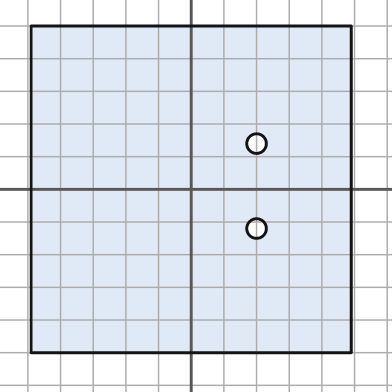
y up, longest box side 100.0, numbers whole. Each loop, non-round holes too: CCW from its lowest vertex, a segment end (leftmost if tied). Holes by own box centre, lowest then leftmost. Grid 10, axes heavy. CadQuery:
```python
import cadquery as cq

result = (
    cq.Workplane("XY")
    .moveTo(-49.0, -50.0)
    .lineTo(49.0, -50.0)
    .lineTo(49.0, 50.0)
    .lineTo(-49.0, 50.0)
    .close()
    .moveTo(20.0, -12.0)
    .circle(3.0)
    .moveTo(20.0, 14.0)
    .circle(3.0)
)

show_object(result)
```